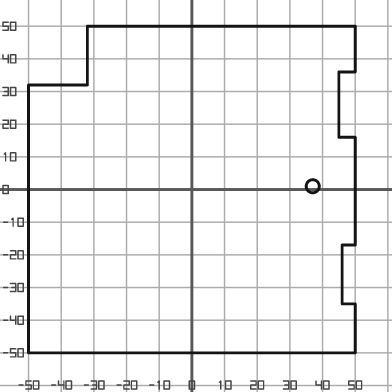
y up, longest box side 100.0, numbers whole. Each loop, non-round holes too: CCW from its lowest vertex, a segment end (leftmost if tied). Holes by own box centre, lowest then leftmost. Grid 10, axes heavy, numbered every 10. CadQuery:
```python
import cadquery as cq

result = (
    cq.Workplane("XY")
    .moveTo(-50.0, -50.0)
    .lineTo(50.0, -50.0)
    .lineTo(50.0, -35.0)
    .lineTo(46.0, -35.0)
    .lineTo(46.0, -17.0)
    .lineTo(50.0, -17.0)
    .lineTo(50.0, 16.0)
    .lineTo(45.0, 16.0)
    .lineTo(45.0, 36.0)
    .lineTo(50.0, 36.0)
    .lineTo(50.0, 50.0)
    .lineTo(-32.0, 50.0)
    .lineTo(-32.0, 32.0)
    .lineTo(-50.0, 32.0)
    .close()
    .moveTo(37.0, 1.0)
    .circle(2.0)
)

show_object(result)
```